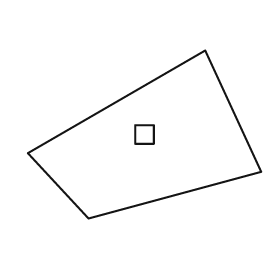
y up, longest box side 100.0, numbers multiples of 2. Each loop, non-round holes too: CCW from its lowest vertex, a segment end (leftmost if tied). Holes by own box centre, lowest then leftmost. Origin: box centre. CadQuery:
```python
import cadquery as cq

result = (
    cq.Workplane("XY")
    .moveTo(-24.0, -36.0)
    .lineTo(50.0, -16.0)
    .lineTo(26.0, 36.0)
    .lineTo(-50.0, -8.0)
    .close()
    .moveTo(-4.0, -4.0)
    .lineTo(4.0, -4.0)
    .lineTo(4.0, 4.0)
    .lineTo(-4.0, 4.0)
    .close()
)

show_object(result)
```